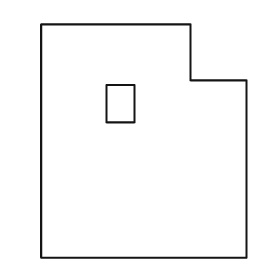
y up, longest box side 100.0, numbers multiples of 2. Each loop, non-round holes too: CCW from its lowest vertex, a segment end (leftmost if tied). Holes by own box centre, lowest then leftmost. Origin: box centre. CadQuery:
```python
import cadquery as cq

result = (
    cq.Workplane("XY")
    .moveTo(-44.0, -50.0)
    .lineTo(44.0, -50.0)
    .lineTo(44.0, 26.0)
    .lineTo(20.0, 26.0)
    .lineTo(20.0, 50.0)
    .lineTo(-44.0, 50.0)
    .close()
    .moveTo(-16.0, 8.0)
    .lineTo(-4.0, 8.0)
    .lineTo(-4.0, 24.0)
    .lineTo(-16.0, 24.0)
    .close()
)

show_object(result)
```